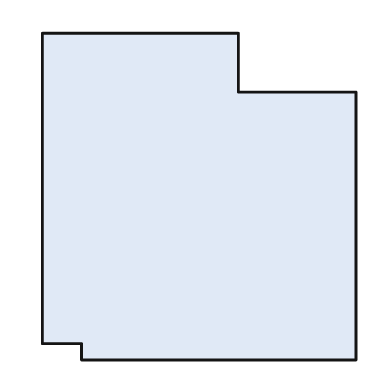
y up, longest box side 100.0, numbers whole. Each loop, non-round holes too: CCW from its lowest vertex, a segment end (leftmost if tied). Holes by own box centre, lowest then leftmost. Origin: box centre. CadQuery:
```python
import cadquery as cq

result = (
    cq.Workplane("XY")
    .moveTo(-36.0, -50.0)
    .lineTo(48.0, -50.0)
    .lineTo(48.0, 32.0)
    .lineTo(12.0, 32.0)
    .lineTo(12.0, 50.0)
    .lineTo(-48.0, 50.0)
    .lineTo(-48.0, -45.0)
    .lineTo(-36.0, -45.0)
    .close()
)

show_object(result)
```